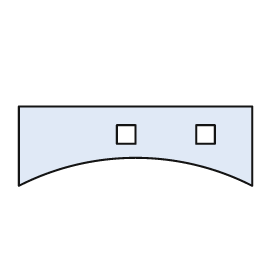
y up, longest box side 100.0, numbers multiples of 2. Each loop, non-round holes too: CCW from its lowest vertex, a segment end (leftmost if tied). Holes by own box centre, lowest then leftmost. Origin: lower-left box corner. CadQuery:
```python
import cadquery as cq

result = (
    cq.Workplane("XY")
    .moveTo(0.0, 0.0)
    .threePointArc((50.0, 12.0), (100.0, 0.0))
    .lineTo(100.0, 34.0)
    .lineTo(0.0, 34.0)
    .close()
    .moveTo(42.0, 18.0)
    .lineTo(50.0, 18.0)
    .lineTo(50.0, 26.0)
    .lineTo(42.0, 26.0)
    .close()
    .moveTo(76.0, 18.0)
    .lineTo(84.0, 18.0)
    .lineTo(84.0, 26.0)
    .lineTo(76.0, 26.0)
    .close()
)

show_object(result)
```